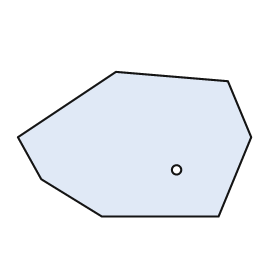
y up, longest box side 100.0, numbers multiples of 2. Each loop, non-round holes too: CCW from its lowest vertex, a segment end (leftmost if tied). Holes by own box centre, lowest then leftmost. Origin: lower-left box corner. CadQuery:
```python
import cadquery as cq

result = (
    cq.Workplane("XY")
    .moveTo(36.0, 0.0)
    .lineTo(86.0, 0.0)
    .lineTo(100.0, 34.0)
    .lineTo(90.0, 58.0)
    .lineTo(42.0, 62.0)
    .lineTo(0.0, 34.0)
    .lineTo(10.0, 16.0)
    .close()
    .moveTo(68.0, 20.0)
    .circle(2.0)
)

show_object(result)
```